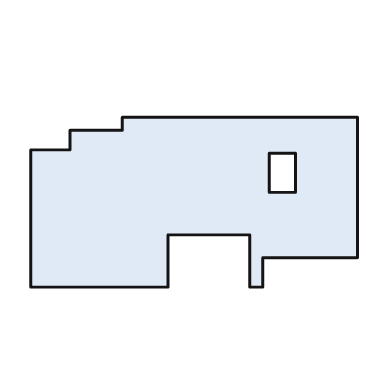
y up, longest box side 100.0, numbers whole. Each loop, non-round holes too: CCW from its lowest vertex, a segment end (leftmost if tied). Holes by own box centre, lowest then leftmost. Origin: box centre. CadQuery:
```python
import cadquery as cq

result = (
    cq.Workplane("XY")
    .moveTo(-50.0, -26.0)
    .lineTo(-8.0, -26.0)
    .lineTo(-8.0, -10.0)
    .lineTo(17.0, -10.0)
    .lineTo(17.0, -26.0)
    .lineTo(21.0, -26.0)
    .lineTo(21.0, -17.0)
    .lineTo(50.0, -17.0)
    .lineTo(50.0, 26.0)
    .lineTo(-22.0, 26.0)
    .lineTo(-22.0, 22.0)
    .lineTo(-38.0, 22.0)
    .lineTo(-38.0, 16.0)
    .lineTo(-50.0, 16.0)
    .close()
    .moveTo(23.0, 3.0)
    .lineTo(31.0, 3.0)
    .lineTo(31.0, 15.0)
    .lineTo(23.0, 15.0)
    .close()
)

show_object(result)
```